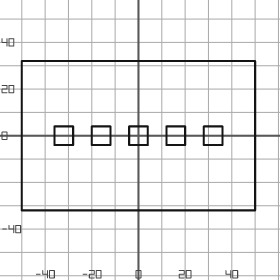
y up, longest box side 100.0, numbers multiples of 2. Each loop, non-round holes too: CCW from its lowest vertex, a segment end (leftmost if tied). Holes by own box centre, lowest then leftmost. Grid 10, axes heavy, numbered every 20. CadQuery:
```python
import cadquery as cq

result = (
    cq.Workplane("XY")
    .moveTo(-50.0, -32.0)
    .lineTo(50.0, -32.0)
    .lineTo(50.0, 32.0)
    .lineTo(-50.0, 32.0)
    .close()
    .moveTo(-36.0, -4.0)
    .lineTo(-28.0, -4.0)
    .lineTo(-28.0, 4.0)
    .lineTo(-36.0, 4.0)
    .close()
    .moveTo(-20.0, -4.0)
    .lineTo(-12.0, -4.0)
    .lineTo(-12.0, 4.0)
    .lineTo(-20.0, 4.0)
    .close()
    .moveTo(-4.0, -4.0)
    .lineTo(4.0, -4.0)
    .lineTo(4.0, 4.0)
    .lineTo(-4.0, 4.0)
    .close()
    .moveTo(12.0, -4.0)
    .lineTo(20.0, -4.0)
    .lineTo(20.0, 4.0)
    .lineTo(12.0, 4.0)
    .close()
    .moveTo(28.0, -4.0)
    .lineTo(36.0, -4.0)
    .lineTo(36.0, 4.0)
    .lineTo(28.0, 4.0)
    .close()
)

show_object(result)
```